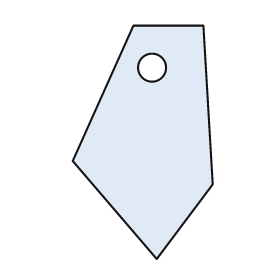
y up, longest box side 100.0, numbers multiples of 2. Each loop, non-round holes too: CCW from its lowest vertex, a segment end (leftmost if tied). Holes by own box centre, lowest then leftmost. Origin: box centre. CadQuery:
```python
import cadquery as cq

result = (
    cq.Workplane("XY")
    .moveTo(6.0, -50.0)
    .lineTo(30.0, -18.0)
    .lineTo(26.0, 50.0)
    .lineTo(-4.0, 50.0)
    .lineTo(-30.0, -8.0)
    .close()
    .moveTo(4.0, 32.0)
    .circle(6.0)
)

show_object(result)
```